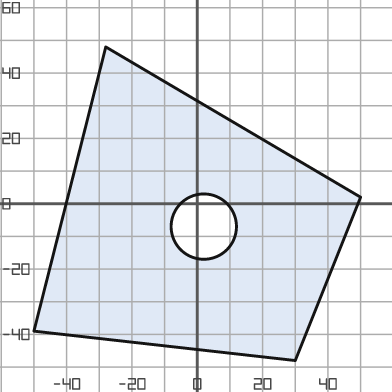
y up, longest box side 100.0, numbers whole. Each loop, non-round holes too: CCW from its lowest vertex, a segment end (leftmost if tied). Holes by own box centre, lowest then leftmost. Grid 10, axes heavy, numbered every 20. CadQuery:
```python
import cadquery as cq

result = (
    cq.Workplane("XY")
    .moveTo(30.0, -48.0)
    .lineTo(50.0, 2.0)
    .lineTo(-28.0, 48.0)
    .lineTo(-50.0, -39.0)
    .close()
    .moveTo(2.0, -7.0)
    .circle(10.0)
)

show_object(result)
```